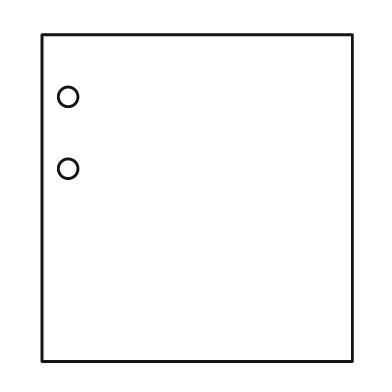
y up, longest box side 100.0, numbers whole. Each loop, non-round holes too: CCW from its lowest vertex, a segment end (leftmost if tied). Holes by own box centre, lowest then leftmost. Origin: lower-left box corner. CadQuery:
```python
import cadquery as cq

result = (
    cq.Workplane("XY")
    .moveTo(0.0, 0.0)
    .lineTo(95.0, 0.0)
    .lineTo(95.0, 100.0)
    .lineTo(0.0, 100.0)
    .close()
    .moveTo(8.0, 59.0)
    .circle(3.0)
    .moveTo(8.0, 81.0)
    .circle(3.0)
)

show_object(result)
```